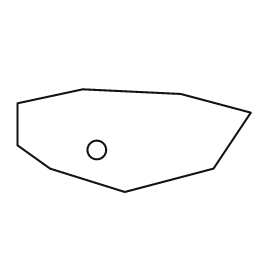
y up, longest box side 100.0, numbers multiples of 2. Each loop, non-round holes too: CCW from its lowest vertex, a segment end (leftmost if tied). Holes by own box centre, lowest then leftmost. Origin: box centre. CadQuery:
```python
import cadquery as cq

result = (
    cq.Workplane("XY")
    .moveTo(-4.0, -22.0)
    .lineTo(34.0, -12.0)
    .lineTo(50.0, 12.0)
    .lineTo(20.0, 20.0)
    .lineTo(-22.0, 22.0)
    .lineTo(-50.0, 16.0)
    .lineTo(-50.0, -2.0)
    .lineTo(-36.0, -12.0)
    .close()
    .moveTo(-16.0, -4.0)
    .circle(4.0)
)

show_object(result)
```